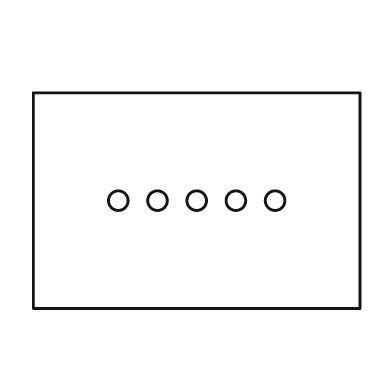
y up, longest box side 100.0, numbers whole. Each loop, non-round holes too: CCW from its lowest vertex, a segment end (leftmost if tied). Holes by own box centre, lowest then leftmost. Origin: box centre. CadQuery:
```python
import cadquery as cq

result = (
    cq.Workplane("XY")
    .moveTo(-50.0, -33.0)
    .lineTo(50.0, -33.0)
    .lineTo(50.0, 33.0)
    .lineTo(-50.0, 33.0)
    .close()
    .moveTo(-24.0, 0.0)
    .circle(3.0)
    .moveTo(-12.0, 0.0)
    .circle(3.0)
    .moveTo(0.0, 0.0)
    .circle(3.0)
    .moveTo(12.0, 0.0)
    .circle(3.0)
    .moveTo(24.0, 0.0)
    .circle(3.0)
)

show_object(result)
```